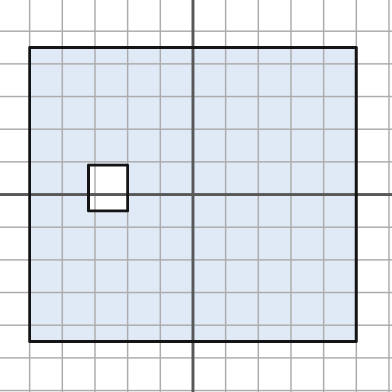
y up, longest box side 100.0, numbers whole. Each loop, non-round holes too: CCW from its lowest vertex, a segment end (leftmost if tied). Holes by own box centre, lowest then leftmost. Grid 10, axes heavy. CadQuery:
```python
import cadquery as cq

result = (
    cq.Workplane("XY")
    .moveTo(-50.0, -45.0)
    .lineTo(50.0, -45.0)
    .lineTo(50.0, 45.0)
    .lineTo(-50.0, 45.0)
    .close()
    .moveTo(-32.0, -5.0)
    .lineTo(-20.0, -5.0)
    .lineTo(-20.0, 9.0)
    .lineTo(-32.0, 9.0)
    .close()
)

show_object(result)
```